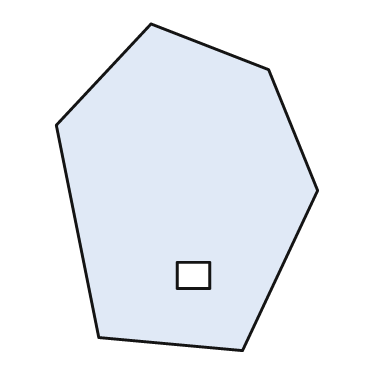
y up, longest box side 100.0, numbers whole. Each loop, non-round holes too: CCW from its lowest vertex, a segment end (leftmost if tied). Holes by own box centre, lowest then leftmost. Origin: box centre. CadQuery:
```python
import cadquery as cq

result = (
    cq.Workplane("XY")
    .moveTo(17.0, -50.0)
    .lineTo(40.0, -1.0)
    .lineTo(25.0, 36.0)
    .lineTo(-11.0, 50.0)
    .lineTo(-40.0, 19.0)
    .lineTo(-27.0, -46.0)
    .close()
    .moveTo(-3.0, -31.0)
    .lineTo(7.0, -31.0)
    .lineTo(7.0, -23.0)
    .lineTo(-3.0, -23.0)
    .close()
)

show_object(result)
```